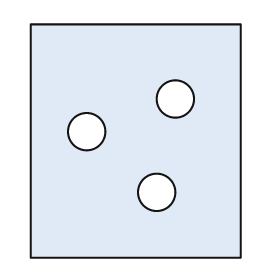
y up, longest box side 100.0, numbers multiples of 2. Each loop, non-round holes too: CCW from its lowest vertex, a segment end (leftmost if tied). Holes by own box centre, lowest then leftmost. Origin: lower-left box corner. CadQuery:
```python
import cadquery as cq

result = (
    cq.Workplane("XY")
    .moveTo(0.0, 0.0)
    .lineTo(90.0, 0.0)
    .lineTo(90.0, 100.0)
    .lineTo(0.0, 100.0)
    .close()
    .moveTo(54.0, 28.0)
    .circle(8.0)
    .moveTo(24.0, 54.0)
    .circle(8.0)
    .moveTo(62.0, 68.0)
    .circle(8.0)
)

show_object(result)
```